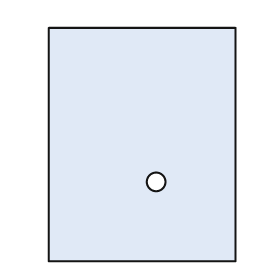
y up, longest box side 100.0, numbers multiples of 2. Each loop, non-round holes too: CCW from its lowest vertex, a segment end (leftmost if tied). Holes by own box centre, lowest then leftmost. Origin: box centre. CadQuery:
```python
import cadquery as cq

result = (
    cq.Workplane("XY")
    .moveTo(-40.0, -50.0)
    .lineTo(40.0, -50.0)
    .lineTo(40.0, 50.0)
    .lineTo(-40.0, 50.0)
    .close()
    .moveTo(6.0, -16.0)
    .circle(4.0)
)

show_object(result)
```